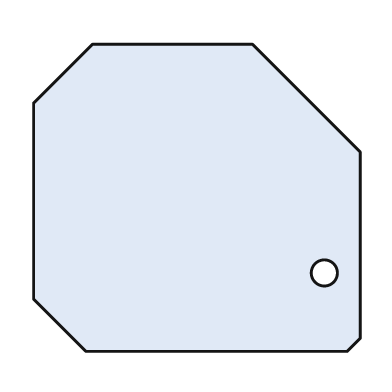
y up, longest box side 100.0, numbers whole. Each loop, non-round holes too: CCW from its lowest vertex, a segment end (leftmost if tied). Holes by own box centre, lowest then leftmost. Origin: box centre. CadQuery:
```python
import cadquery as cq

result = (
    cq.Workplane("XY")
    .moveTo(-34.0, -47.0)
    .lineTo(46.0, -47.0)
    .lineTo(50.0, -43.0)
    .lineTo(50.0, 14.0)
    .lineTo(17.0, 47.0)
    .lineTo(-32.0, 47.0)
    .lineTo(-50.0, 29.0)
    .lineTo(-50.0, -31.0)
    .close()
    .moveTo(39.0, -23.0)
    .circle(4.0)
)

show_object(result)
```